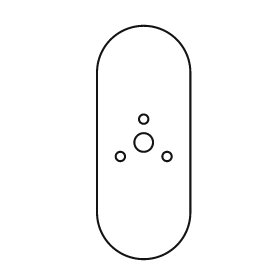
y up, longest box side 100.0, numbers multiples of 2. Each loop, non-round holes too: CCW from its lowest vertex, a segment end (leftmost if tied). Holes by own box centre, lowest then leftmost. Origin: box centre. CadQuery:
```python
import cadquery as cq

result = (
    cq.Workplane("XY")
    .moveTo(-20.0, -30.0)
    .threePointArc((0.0, -50.0), (20.0, -30.0))
    .lineTo(20.0, 30.0)
    .threePointArc((0.0, 50.0), (-20.0, 30.0))
    .close()
    .moveTo(-10.0, -6.0)
    .circle(2.0)
    .moveTo(10.0, -6.0)
    .circle(2.0)
    .moveTo(0.0, 0.0)
    .circle(4.0)
    .moveTo(0.0, 10.0)
    .circle(2.0)
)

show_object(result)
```